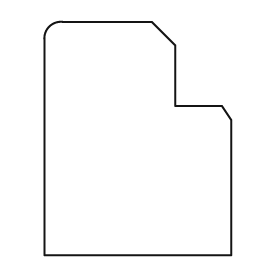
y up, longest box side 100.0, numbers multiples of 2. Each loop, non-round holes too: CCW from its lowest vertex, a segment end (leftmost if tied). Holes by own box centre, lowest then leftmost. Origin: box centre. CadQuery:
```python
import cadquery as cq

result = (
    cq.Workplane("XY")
    .moveTo(-40.0, -50.0)
    .lineTo(40.0, -50.0)
    .lineTo(40.0, 8.0)
    .lineTo(36.0, 14.0)
    .lineTo(16.0, 14.0)
    .lineTo(16.0, 40.0)
    .lineTo(6.0, 50.0)
    .lineTo(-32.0, 50.0)
    .threePointArc((-38.0, 48.0), (-40.0, 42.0))
    .close()
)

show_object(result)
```